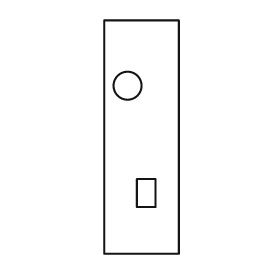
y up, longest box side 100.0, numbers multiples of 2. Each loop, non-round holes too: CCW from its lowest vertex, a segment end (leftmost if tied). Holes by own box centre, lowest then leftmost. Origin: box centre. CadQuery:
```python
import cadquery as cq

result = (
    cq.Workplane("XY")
    .moveTo(-16.0, -50.0)
    .lineTo(16.0, -50.0)
    .lineTo(16.0, 50.0)
    .lineTo(-16.0, 50.0)
    .close()
    .moveTo(-2.0, -30.0)
    .lineTo(6.0, -30.0)
    .lineTo(6.0, -18.0)
    .lineTo(-2.0, -18.0)
    .close()
    .moveTo(-6.0, 22.0)
    .circle(6.0)
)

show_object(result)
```